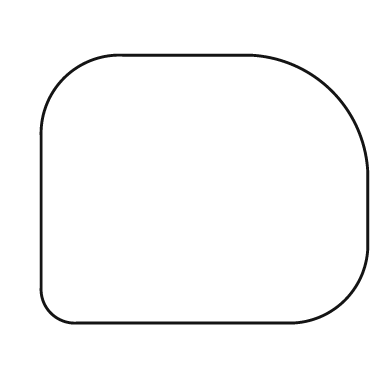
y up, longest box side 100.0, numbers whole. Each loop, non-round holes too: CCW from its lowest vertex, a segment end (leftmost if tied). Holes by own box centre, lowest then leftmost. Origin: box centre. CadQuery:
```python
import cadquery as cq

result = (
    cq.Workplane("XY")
    .moveTo(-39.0, -41.0)
    .lineTo(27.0, -41.0)
    .threePointArc((43.0, -34.0), (50.0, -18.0))
    .lineTo(50.0, 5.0)
    .threePointArc((39.0, 30.0), (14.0, 41.0))
    .lineTo(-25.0, 41.0)
    .threePointArc((-43.0, 34.0), (-50.0, 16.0))
    .lineTo(-50.0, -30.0)
    .threePointArc((-47.0, -38.0), (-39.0, -41.0))
    .close()
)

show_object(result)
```